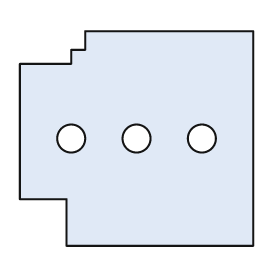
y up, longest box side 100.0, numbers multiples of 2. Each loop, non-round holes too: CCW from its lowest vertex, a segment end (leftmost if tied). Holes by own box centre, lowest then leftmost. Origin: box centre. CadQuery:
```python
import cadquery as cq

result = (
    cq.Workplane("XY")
    .moveTo(-30.0, -46.0)
    .lineTo(50.0, -46.0)
    .lineTo(50.0, 46.0)
    .lineTo(-22.0, 46.0)
    .lineTo(-22.0, 38.0)
    .lineTo(-28.0, 38.0)
    .lineTo(-28.0, 32.0)
    .lineTo(-50.0, 32.0)
    .lineTo(-50.0, -26.0)
    .lineTo(-30.0, -26.0)
    .close()
    .moveTo(-28.0, 0.0)
    .circle(6.0)
    .moveTo(0.0, 0.0)
    .circle(6.0)
    .moveTo(28.0, 0.0)
    .circle(6.0)
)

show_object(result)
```